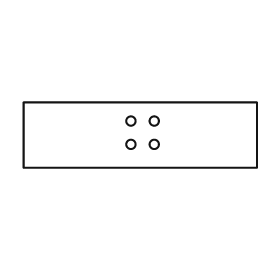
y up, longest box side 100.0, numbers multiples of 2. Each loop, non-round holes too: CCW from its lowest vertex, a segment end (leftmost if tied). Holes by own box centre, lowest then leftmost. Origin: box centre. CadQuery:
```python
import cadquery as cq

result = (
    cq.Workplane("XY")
    .moveTo(-50.0, -14.0)
    .lineTo(50.0, -14.0)
    .lineTo(50.0, 14.0)
    .lineTo(-50.0, 14.0)
    .close()
    .moveTo(-4.0, -4.0)
    .circle(2.0)
    .moveTo(6.0, -4.0)
    .circle(2.0)
    .moveTo(-4.0, 6.0)
    .circle(2.0)
    .moveTo(6.0, 6.0)
    .circle(2.0)
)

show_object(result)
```